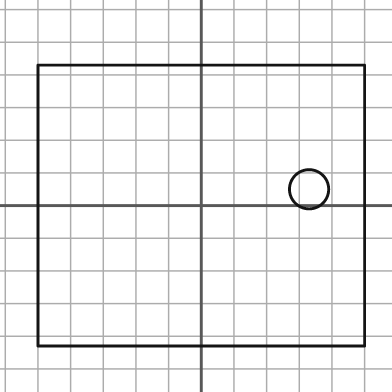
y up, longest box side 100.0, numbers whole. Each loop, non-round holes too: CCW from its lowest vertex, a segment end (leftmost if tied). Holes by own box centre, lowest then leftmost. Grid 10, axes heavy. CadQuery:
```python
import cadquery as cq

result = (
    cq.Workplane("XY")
    .moveTo(-50.0, -43.0)
    .lineTo(50.0, -43.0)
    .lineTo(50.0, 43.0)
    .lineTo(-50.0, 43.0)
    .close()
    .moveTo(33.0, 5.0)
    .circle(6.0)
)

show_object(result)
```